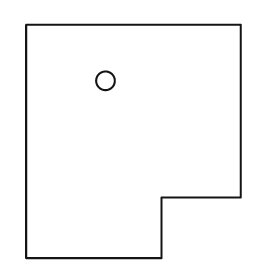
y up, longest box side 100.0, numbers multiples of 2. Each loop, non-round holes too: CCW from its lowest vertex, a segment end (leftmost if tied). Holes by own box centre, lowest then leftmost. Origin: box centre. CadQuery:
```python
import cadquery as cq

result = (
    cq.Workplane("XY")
    .moveTo(-46.0, -50.0)
    .lineTo(12.0, -50.0)
    .lineTo(12.0, -24.0)
    .lineTo(46.0, -24.0)
    .lineTo(46.0, 50.0)
    .lineTo(-46.0, 50.0)
    .close()
    .moveTo(-12.0, 26.0)
    .circle(4.0)
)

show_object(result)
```